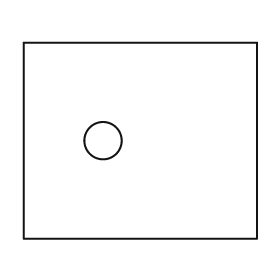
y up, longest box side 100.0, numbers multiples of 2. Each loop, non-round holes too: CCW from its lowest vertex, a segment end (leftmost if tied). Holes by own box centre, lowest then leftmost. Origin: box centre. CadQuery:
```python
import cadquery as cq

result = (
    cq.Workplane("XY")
    .moveTo(-50.0, -42.0)
    .lineTo(50.0, -42.0)
    .lineTo(50.0, 42.0)
    .lineTo(-50.0, 42.0)
    .close()
    .moveTo(-16.0, 0.0)
    .circle(8.0)
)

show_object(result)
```